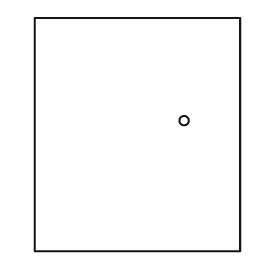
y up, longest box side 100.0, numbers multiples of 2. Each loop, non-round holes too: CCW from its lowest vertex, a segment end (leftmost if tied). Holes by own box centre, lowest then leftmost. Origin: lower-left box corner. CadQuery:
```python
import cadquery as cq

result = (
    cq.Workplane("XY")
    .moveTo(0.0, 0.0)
    .lineTo(88.0, 0.0)
    .lineTo(88.0, 100.0)
    .lineTo(0.0, 100.0)
    .close()
    .moveTo(64.0, 56.0)
    .circle(2.0)
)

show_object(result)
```